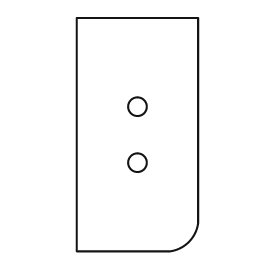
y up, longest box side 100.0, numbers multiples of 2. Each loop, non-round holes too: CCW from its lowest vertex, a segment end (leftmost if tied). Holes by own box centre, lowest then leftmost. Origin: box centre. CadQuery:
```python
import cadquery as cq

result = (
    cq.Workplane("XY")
    .moveTo(-26.0, -50.0)
    .lineTo(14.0, -50.0)
    .threePointArc((22.0, -46.0), (26.0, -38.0))
    .lineTo(26.0, 50.0)
    .lineTo(-26.0, 50.0)
    .close()
    .moveTo(0.0, -12.0)
    .circle(4.0)
    .moveTo(0.0, 12.0)
    .circle(4.0)
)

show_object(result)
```